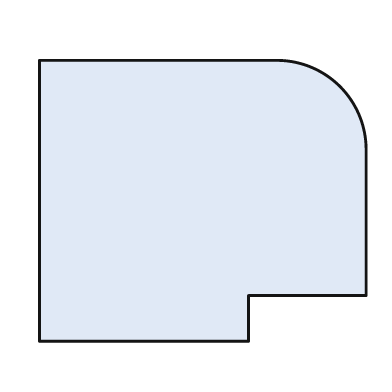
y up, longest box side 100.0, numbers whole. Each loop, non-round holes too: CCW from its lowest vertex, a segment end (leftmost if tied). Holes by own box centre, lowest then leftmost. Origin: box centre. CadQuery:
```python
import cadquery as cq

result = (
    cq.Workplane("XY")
    .moveTo(-50.0, -43.0)
    .lineTo(14.0, -43.0)
    .lineTo(14.0, -29.0)
    .lineTo(50.0, -29.0)
    .lineTo(50.0, 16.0)
    .threePointArc((42.0, 35.0), (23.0, 43.0))
    .lineTo(-50.0, 43.0)
    .close()
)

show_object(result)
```